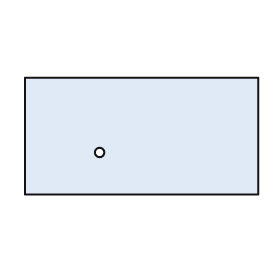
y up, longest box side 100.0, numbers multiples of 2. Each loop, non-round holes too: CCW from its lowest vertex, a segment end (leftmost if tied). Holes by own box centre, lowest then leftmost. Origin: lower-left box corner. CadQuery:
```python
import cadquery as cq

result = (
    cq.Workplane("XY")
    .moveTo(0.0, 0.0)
    .lineTo(100.0, 0.0)
    .lineTo(100.0, 50.0)
    .lineTo(0.0, 50.0)
    .close()
    .moveTo(32.0, 18.0)
    .circle(2.0)
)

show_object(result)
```